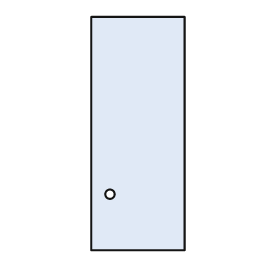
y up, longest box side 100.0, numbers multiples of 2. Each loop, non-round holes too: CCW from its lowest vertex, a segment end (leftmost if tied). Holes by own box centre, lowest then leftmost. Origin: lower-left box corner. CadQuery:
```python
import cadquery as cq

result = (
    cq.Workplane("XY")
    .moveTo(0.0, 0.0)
    .lineTo(40.0, 0.0)
    .lineTo(40.0, 100.0)
    .lineTo(0.0, 100.0)
    .close()
    .moveTo(8.0, 24.0)
    .circle(2.0)
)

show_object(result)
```